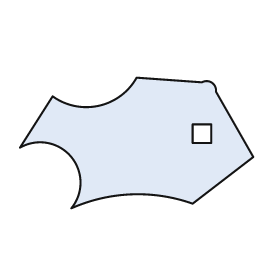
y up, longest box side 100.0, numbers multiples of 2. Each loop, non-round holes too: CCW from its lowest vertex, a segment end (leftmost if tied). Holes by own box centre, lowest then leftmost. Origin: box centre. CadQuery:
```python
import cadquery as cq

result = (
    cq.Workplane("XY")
    .moveTo(-28.0, -28.0)
    .threePointArc((-2.0, -22.0), (24.0, -26.0))
    .lineTo(50.0, -6.0)
    .lineTo(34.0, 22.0)
    .threePointArc((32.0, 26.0), (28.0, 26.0))
    .lineTo(0.0, 28.0)
    .threePointArc((-16.0, 16.0), (-36.0, 20.0))
    .lineTo(-50.0, -2.0)
    .threePointArc((-28.0, -6.0), (-28.0, -28.0))
    .close()
    .moveTo(24.0, 0.0)
    .lineTo(32.0, 0.0)
    .lineTo(32.0, 8.0)
    .lineTo(24.0, 8.0)
    .close()
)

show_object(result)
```